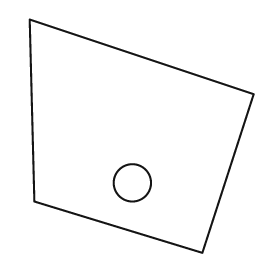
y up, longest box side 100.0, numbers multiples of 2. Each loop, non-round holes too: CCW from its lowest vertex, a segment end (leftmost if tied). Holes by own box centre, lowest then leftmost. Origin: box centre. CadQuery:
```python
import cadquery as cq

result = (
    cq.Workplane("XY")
    .moveTo(26.0, -50.0)
    .lineTo(48.0, 18.0)
    .lineTo(-48.0, 50.0)
    .lineTo(-46.0, -28.0)
    .close()
    .moveTo(-4.0, -20.0)
    .circle(8.0)
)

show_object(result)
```